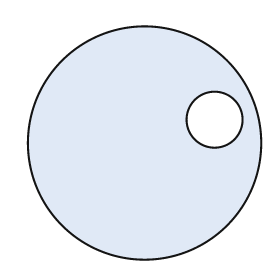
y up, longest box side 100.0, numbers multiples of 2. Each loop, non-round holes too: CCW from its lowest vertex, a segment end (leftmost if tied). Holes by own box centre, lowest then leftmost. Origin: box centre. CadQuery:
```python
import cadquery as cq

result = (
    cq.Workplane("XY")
    .moveTo(0.0, 0.0)
    .circle(50.0)
    .moveTo(30.0, 10.0)
    .circle(12.0)
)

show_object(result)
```